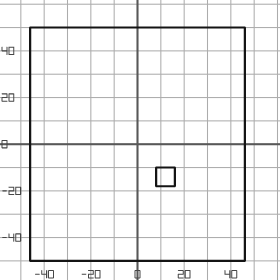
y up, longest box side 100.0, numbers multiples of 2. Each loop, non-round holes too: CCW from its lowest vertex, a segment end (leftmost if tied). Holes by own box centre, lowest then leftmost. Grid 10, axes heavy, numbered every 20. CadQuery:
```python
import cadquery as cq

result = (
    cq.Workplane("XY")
    .moveTo(-46.0, -50.0)
    .lineTo(46.0, -50.0)
    .lineTo(46.0, 50.0)
    .lineTo(-46.0, 50.0)
    .close()
    .moveTo(8.0, -18.0)
    .lineTo(16.0, -18.0)
    .lineTo(16.0, -10.0)
    .lineTo(8.0, -10.0)
    .close()
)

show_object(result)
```